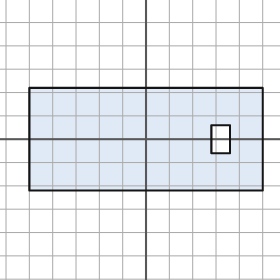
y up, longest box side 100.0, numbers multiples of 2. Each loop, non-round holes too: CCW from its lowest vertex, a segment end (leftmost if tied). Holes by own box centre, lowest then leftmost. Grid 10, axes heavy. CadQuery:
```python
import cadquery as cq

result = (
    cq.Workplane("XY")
    .moveTo(-50.0, -22.0)
    .lineTo(50.0, -22.0)
    .lineTo(50.0, 22.0)
    .lineTo(-50.0, 22.0)
    .close()
    .moveTo(28.0, -6.0)
    .lineTo(36.0, -6.0)
    .lineTo(36.0, 6.0)
    .lineTo(28.0, 6.0)
    .close()
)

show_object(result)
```